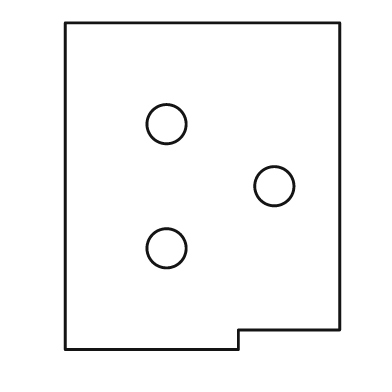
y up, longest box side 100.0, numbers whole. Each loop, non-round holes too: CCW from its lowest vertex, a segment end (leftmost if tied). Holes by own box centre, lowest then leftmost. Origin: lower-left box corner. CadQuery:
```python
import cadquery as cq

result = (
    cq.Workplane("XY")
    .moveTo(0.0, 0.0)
    .lineTo(53.0, 0.0)
    .lineTo(53.0, 6.0)
    .lineTo(84.0, 6.0)
    .lineTo(84.0, 100.0)
    .lineTo(0.0, 100.0)
    .close()
    .moveTo(31.0, 31.0)
    .circle(6.0)
    .moveTo(64.0, 50.0)
    .circle(6.0)
    .moveTo(31.0, 69.0)
    .circle(6.0)
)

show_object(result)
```